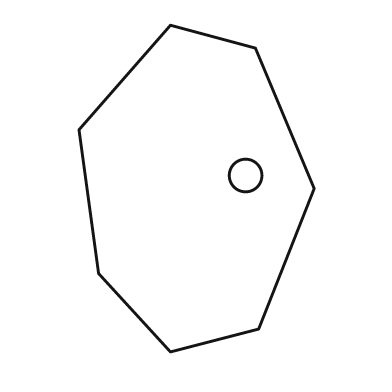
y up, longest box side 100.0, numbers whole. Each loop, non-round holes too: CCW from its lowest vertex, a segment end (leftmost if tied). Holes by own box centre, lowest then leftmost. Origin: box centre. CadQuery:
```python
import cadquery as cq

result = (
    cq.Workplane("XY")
    .moveTo(-8.0, -50.0)
    .lineTo(19.0, -43.0)
    .lineTo(36.0, 0.0)
    .lineTo(18.0, 43.0)
    .lineTo(-8.0, 50.0)
    .lineTo(-36.0, 18.0)
    .lineTo(-30.0, -26.0)
    .close()
    .moveTo(15.0, 4.0)
    .circle(5.0)
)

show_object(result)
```